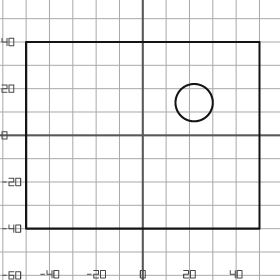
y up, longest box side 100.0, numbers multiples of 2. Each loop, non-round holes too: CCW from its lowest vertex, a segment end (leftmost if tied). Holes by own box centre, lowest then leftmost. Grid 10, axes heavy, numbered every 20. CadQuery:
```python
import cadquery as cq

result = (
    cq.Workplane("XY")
    .moveTo(-50.0, -40.0)
    .lineTo(50.0, -40.0)
    .lineTo(50.0, 40.0)
    .lineTo(-50.0, 40.0)
    .close()
    .moveTo(22.0, 14.0)
    .circle(8.0)
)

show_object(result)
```